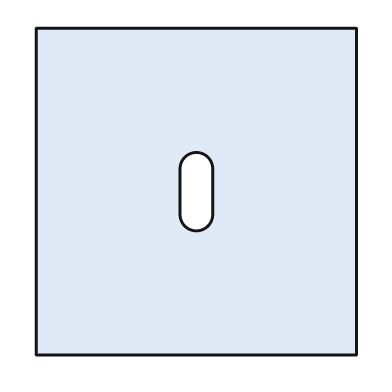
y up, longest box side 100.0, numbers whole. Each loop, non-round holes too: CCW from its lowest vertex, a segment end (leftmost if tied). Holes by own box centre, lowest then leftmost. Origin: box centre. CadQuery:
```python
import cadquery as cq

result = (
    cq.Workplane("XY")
    .moveTo(-49.0, -50.0)
    .lineTo(49.0, -50.0)
    .lineTo(49.0, 50.0)
    .lineTo(-49.0, 50.0)
    .close()
    .moveTo(-5.0, -7.0)
    .threePointArc((0.0, -12.0), (5.0, -7.0))
    .lineTo(5.0, 7.0)
    .threePointArc((0.0, 12.0), (-5.0, 7.0))
    .close()
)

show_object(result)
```